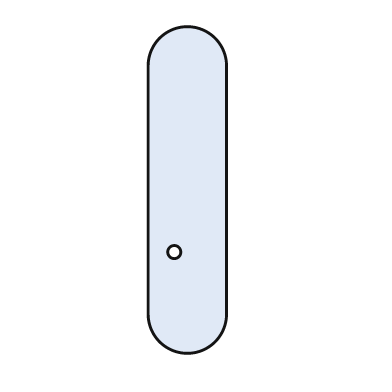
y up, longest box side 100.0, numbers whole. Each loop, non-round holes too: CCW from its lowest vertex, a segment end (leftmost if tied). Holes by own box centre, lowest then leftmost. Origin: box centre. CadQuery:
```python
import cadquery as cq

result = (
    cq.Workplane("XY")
    .moveTo(-12.0, -38.0)
    .threePointArc((0.0, -50.0), (12.0, -38.0))
    .lineTo(12.0, 38.0)
    .threePointArc((0.0, 50.0), (-12.0, 38.0))
    .close()
    .moveTo(-4.0, -19.0)
    .circle(2.0)
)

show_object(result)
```